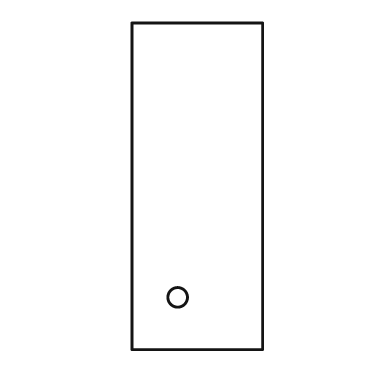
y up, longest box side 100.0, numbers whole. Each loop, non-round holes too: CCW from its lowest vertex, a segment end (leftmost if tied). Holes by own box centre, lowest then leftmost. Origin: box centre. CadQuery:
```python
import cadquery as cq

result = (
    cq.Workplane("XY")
    .moveTo(-20.0, -50.0)
    .lineTo(20.0, -50.0)
    .lineTo(20.0, 50.0)
    .lineTo(-20.0, 50.0)
    .close()
    .moveTo(-6.0, -34.0)
    .circle(3.0)
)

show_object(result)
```